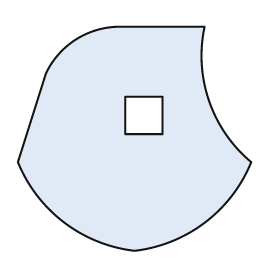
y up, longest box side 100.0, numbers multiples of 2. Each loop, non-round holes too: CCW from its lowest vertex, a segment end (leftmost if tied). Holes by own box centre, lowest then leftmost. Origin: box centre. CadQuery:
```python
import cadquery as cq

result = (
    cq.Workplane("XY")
    .moveTo(0.0, -48.0)
    .threePointArc((30.0, -36.0), (50.0, -10.0))
    .threePointArc((32.0, 16.0), (30.0, 48.0))
    .lineTo(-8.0, 48.0)
    .threePointArc((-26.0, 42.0), (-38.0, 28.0))
    .lineTo(-50.0, -10.0)
    .threePointArc((-30.0, -36.0), (0.0, -48.0))
    .close()
    .moveTo(-4.0, 2.0)
    .lineTo(12.0, 2.0)
    .lineTo(12.0, 18.0)
    .lineTo(-4.0, 18.0)
    .close()
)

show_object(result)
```